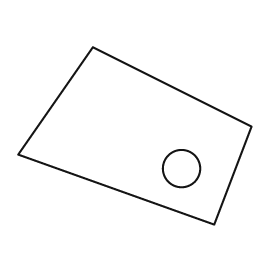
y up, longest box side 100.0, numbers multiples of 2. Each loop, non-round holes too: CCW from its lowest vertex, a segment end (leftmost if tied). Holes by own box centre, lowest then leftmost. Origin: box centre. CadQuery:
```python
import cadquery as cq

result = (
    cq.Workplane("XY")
    .moveTo(34.0, -38.0)
    .lineTo(50.0, 4.0)
    .lineTo(-18.0, 38.0)
    .lineTo(-50.0, -8.0)
    .close()
    .moveTo(20.0, -14.0)
    .circle(8.0)
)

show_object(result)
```